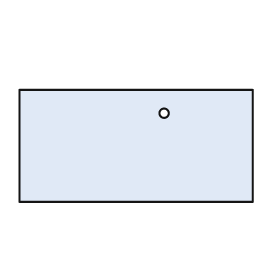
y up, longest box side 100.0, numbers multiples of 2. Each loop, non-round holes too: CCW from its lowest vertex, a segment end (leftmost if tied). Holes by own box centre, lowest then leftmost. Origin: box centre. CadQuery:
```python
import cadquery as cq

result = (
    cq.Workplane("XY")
    .moveTo(-50.0, -24.0)
    .lineTo(50.0, -24.0)
    .lineTo(50.0, 24.0)
    .lineTo(-50.0, 24.0)
    .close()
    .moveTo(12.0, 14.0)
    .circle(2.0)
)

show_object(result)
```